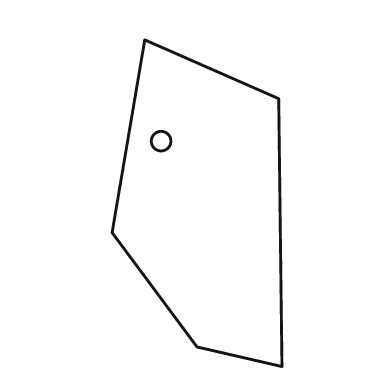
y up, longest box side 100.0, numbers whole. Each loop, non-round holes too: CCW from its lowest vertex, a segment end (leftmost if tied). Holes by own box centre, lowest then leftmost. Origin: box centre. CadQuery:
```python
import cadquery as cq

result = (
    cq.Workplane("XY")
    .moveTo(26.0, -50.0)
    .lineTo(25.0, 32.0)
    .lineTo(-16.0, 50.0)
    .lineTo(-26.0, -9.0)
    .lineTo(0.0, -44.0)
    .close()
    .moveTo(-11.0, 19.0)
    .circle(3.0)
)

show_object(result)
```